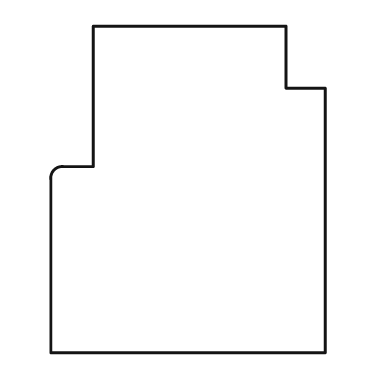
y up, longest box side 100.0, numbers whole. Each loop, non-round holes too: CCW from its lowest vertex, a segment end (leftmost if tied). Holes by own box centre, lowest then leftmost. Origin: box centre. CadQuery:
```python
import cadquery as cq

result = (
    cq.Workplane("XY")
    .moveTo(-42.0, -50.0)
    .lineTo(42.0, -50.0)
    .lineTo(42.0, 31.0)
    .lineTo(30.0, 31.0)
    .lineTo(30.0, 50.0)
    .lineTo(-29.0, 50.0)
    .lineTo(-29.0, 7.0)
    .lineTo(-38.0, 7.0)
    .threePointArc((-41.0, 6.0), (-42.0, 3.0))
    .close()
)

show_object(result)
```